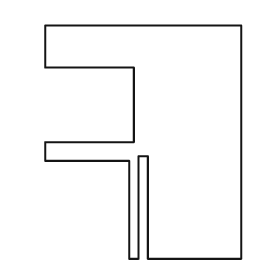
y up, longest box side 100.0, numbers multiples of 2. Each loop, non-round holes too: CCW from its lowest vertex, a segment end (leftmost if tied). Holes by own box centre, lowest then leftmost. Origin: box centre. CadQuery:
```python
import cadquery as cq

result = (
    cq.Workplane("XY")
    .moveTo(-6.0, -50.0)
    .lineTo(-2.0, -50.0)
    .lineTo(-2.0, -6.0)
    .lineTo(2.0, -6.0)
    .lineTo(2.0, -50.0)
    .lineTo(42.0, -50.0)
    .lineTo(42.0, 50.0)
    .lineTo(-42.0, 50.0)
    .lineTo(-42.0, 32.0)
    .lineTo(-4.0, 32.0)
    .lineTo(-4.0, 0.0)
    .lineTo(-42.0, 0.0)
    .lineTo(-42.0, -8.0)
    .lineTo(-6.0, -8.0)
    .close()
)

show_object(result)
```